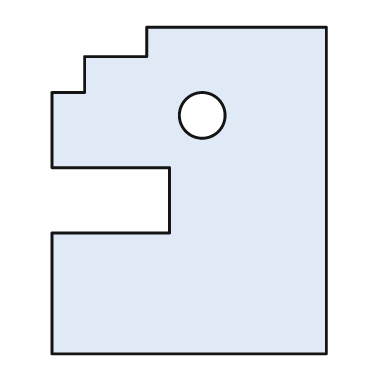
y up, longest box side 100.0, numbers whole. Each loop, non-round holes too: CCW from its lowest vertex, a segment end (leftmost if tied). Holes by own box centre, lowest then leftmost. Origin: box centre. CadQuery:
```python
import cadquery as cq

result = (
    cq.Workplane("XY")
    .moveTo(-42.0, -50.0)
    .lineTo(42.0, -50.0)
    .lineTo(42.0, 50.0)
    .lineTo(-13.0, 50.0)
    .lineTo(-13.0, 41.0)
    .lineTo(-32.0, 41.0)
    .lineTo(-32.0, 30.0)
    .lineTo(-42.0, 30.0)
    .lineTo(-42.0, 7.0)
    .lineTo(-6.0, 7.0)
    .lineTo(-6.0, -13.0)
    .lineTo(-42.0, -13.0)
    .close()
    .moveTo(4.0, 23.0)
    .circle(7.0)
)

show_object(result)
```